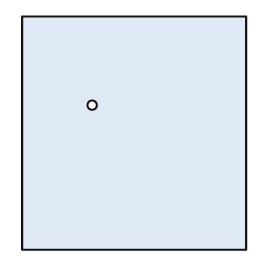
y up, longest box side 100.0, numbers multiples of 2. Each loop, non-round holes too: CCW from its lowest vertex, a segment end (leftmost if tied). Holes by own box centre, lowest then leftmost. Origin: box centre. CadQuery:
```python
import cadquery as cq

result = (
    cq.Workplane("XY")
    .moveTo(-48.0, -50.0)
    .lineTo(48.0, -50.0)
    .lineTo(48.0, 50.0)
    .lineTo(-48.0, 50.0)
    .close()
    .moveTo(-18.0, 12.0)
    .circle(2.0)
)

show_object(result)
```